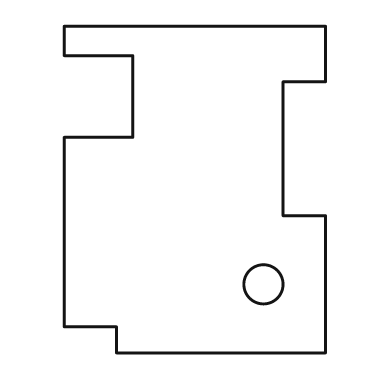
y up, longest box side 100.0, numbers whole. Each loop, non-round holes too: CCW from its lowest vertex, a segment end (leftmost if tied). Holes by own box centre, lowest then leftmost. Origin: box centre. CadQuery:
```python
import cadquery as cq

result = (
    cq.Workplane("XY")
    .moveTo(-24.0, -50.0)
    .lineTo(40.0, -50.0)
    .lineTo(40.0, -8.0)
    .lineTo(27.0, -8.0)
    .lineTo(27.0, 33.0)
    .lineTo(40.0, 33.0)
    .lineTo(40.0, 50.0)
    .lineTo(-40.0, 50.0)
    .lineTo(-40.0, 41.0)
    .lineTo(-19.0, 41.0)
    .lineTo(-19.0, 16.0)
    .lineTo(-40.0, 16.0)
    .lineTo(-40.0, -42.0)
    .lineTo(-24.0, -42.0)
    .close()
    .moveTo(21.0, -29.0)
    .circle(6.0)
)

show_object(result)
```